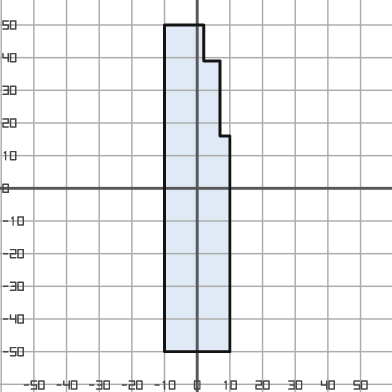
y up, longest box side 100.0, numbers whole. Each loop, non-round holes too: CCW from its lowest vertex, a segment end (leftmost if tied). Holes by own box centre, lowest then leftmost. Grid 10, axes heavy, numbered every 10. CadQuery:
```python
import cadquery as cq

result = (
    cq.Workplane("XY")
    .moveTo(-10.0, -50.0)
    .lineTo(10.0, -50.0)
    .lineTo(10.0, 16.0)
    .lineTo(7.0, 16.0)
    .lineTo(7.0, 39.0)
    .lineTo(2.0, 39.0)
    .lineTo(2.0, 50.0)
    .lineTo(-10.0, 50.0)
    .close()
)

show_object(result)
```